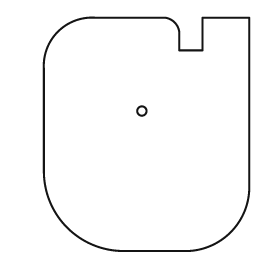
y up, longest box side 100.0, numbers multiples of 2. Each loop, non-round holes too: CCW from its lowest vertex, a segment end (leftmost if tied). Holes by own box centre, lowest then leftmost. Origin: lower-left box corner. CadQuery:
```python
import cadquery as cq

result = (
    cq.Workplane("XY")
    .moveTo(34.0, 0.0)
    .lineTo(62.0, 0.0)
    .threePointArc((80.0, 8.0), (88.0, 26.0))
    .lineTo(88.0, 100.0)
    .lineTo(68.0, 100.0)
    .lineTo(68.0, 86.0)
    .lineTo(58.0, 86.0)
    .lineTo(58.0, 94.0)
    .threePointArc((56.0, 98.0), (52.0, 100.0))
    .lineTo(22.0, 100.0)
    .threePointArc((6.0, 94.0), (0.0, 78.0))
    .lineTo(0.0, 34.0)
    .threePointArc((10.0, 10.0), (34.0, 0.0))
    .close()
    .moveTo(42.0, 60.0)
    .circle(2.0)
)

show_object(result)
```